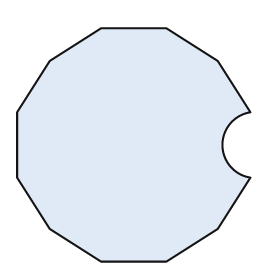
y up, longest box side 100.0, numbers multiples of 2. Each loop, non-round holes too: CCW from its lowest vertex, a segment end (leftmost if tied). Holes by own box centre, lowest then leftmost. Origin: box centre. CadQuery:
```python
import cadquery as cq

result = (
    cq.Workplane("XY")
    .moveTo(-14.0, -50.0)
    .lineTo(14.0, -50.0)
    .lineTo(36.0, -36.0)
    .lineTo(50.0, -14.0)
    .threePointArc((38.0, 0.0), (50.0, 14.0))
    .lineTo(36.0, 36.0)
    .lineTo(14.0, 50.0)
    .lineTo(-14.0, 50.0)
    .lineTo(-36.0, 36.0)
    .lineTo(-50.0, 14.0)
    .lineTo(-50.0, -14.0)
    .lineTo(-36.0, -36.0)
    .close()
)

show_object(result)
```